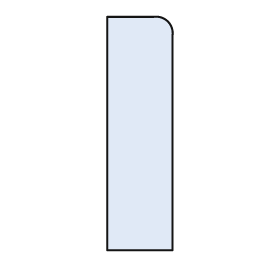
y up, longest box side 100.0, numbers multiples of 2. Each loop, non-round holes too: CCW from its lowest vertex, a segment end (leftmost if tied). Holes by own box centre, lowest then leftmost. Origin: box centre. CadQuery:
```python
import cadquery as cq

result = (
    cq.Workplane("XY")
    .moveTo(-14.0, -50.0)
    .lineTo(14.0, -50.0)
    .lineTo(14.0, 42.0)
    .threePointArc((12.0, 48.0), (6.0, 50.0))
    .lineTo(-14.0, 50.0)
    .close()
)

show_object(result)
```